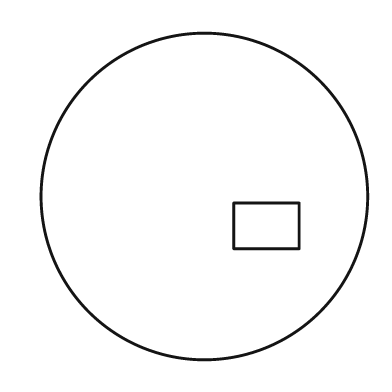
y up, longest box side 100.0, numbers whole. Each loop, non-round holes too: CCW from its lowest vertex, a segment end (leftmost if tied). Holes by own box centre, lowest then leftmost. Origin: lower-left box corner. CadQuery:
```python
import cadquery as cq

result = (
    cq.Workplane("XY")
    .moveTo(50.0, 50.0)
    .circle(50.0)
    .moveTo(59.0, 34.0)
    .lineTo(79.0, 34.0)
    .lineTo(79.0, 48.0)
    .lineTo(59.0, 48.0)
    .close()
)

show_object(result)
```